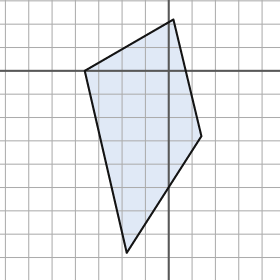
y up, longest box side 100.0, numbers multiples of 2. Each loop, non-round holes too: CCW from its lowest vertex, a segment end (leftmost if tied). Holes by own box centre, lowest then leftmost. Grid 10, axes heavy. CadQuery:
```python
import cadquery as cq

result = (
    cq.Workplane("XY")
    .moveTo(-18.0, -78.0)
    .lineTo(14.0, -28.0)
    .lineTo(2.0, 22.0)
    .lineTo(-36.0, 0.0)
    .close()
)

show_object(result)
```